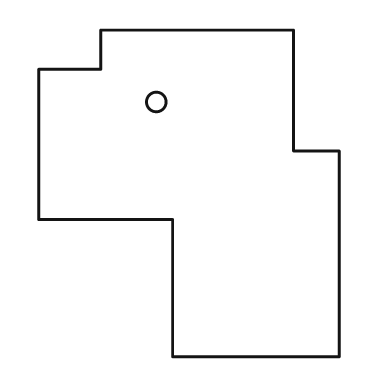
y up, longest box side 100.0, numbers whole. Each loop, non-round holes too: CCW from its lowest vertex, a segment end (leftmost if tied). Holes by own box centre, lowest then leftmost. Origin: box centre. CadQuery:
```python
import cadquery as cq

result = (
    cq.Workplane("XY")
    .moveTo(-5.0, -50.0)
    .lineTo(46.0, -50.0)
    .lineTo(46.0, 13.0)
    .lineTo(32.0, 13.0)
    .lineTo(32.0, 50.0)
    .lineTo(-27.0, 50.0)
    .lineTo(-27.0, 38.0)
    .lineTo(-46.0, 38.0)
    .lineTo(-46.0, -8.0)
    .lineTo(-5.0, -8.0)
    .close()
    .moveTo(-10.0, 28.0)
    .circle(3.0)
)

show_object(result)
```